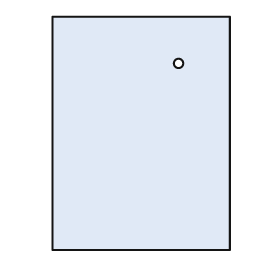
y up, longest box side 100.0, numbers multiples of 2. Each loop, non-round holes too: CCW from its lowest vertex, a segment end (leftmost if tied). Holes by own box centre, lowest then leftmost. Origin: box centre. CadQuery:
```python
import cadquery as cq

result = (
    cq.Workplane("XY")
    .moveTo(-38.0, -50.0)
    .lineTo(38.0, -50.0)
    .lineTo(38.0, 50.0)
    .lineTo(-38.0, 50.0)
    .close()
    .moveTo(16.0, 30.0)
    .circle(2.0)
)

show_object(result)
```